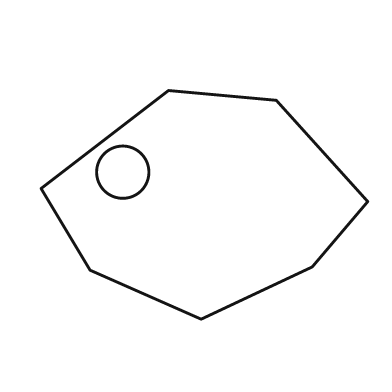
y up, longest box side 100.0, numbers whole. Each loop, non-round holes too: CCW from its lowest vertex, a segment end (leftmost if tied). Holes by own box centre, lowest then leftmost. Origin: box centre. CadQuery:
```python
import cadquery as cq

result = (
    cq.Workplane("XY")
    .moveTo(-1.0, -35.0)
    .lineTo(33.0, -19.0)
    .lineTo(50.0, 1.0)
    .lineTo(22.0, 32.0)
    .lineTo(-11.0, 35.0)
    .lineTo(-50.0, 5.0)
    .lineTo(-35.0, -20.0)
    .close()
    .moveTo(-25.0, 10.0)
    .circle(8.0)
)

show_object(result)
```